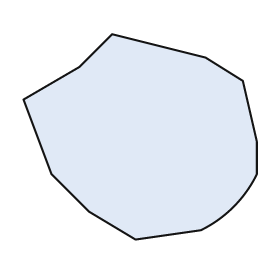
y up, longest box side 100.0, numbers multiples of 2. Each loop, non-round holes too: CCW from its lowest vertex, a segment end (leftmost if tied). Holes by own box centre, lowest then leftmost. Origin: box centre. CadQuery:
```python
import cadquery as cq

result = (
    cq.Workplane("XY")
    .moveTo(-2.0, -44.0)
    .lineTo(26.0, -40.0)
    .threePointArc((40.0, -30.0), (50.0, -16.0))
    .lineTo(50.0, -2.0)
    .lineTo(44.0, 24.0)
    .lineTo(28.0, 34.0)
    .lineTo(-12.0, 44.0)
    .lineTo(-26.0, 30.0)
    .lineTo(-50.0, 16.0)
    .lineTo(-38.0, -16.0)
    .lineTo(-22.0, -32.0)
    .close()
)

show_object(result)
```